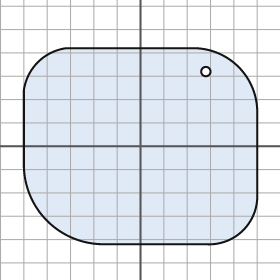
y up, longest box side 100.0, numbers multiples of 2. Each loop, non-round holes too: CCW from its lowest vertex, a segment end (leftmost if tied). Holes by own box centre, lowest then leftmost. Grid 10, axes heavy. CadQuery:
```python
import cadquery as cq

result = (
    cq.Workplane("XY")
    .moveTo(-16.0, -42.0)
    .lineTo(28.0, -42.0)
    .threePointArc((44.0, -36.0), (50.0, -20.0))
    .lineTo(50.0, 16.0)
    .threePointArc((42.0, 34.0), (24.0, 42.0))
    .lineTo(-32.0, 42.0)
    .threePointArc((-44.0, 36.0), (-50.0, 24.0))
    .lineTo(-50.0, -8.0)
    .threePointArc((-40.0, -32.0), (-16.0, -42.0))
    .close()
    .moveTo(28.0, 32.0)
    .circle(2.0)
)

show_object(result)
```